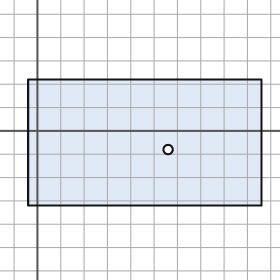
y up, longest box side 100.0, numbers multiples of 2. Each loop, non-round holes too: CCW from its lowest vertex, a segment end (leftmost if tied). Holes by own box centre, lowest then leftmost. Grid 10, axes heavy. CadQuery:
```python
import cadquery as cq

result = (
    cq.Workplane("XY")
    .moveTo(-4.0, -32.0)
    .lineTo(96.0, -32.0)
    .lineTo(96.0, 22.0)
    .lineTo(-4.0, 22.0)
    .close()
    .moveTo(56.0, -8.0)
    .circle(2.0)
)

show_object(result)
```